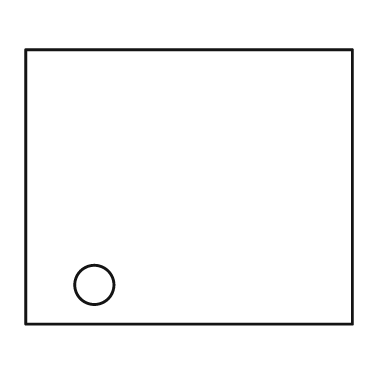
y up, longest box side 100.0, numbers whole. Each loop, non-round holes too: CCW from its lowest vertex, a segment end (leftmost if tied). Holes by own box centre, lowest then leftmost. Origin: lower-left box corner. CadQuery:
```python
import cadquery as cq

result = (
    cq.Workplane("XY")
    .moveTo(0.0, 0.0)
    .lineTo(100.0, 0.0)
    .lineTo(100.0, 84.0)
    .lineTo(0.0, 84.0)
    .close()
    .moveTo(21.0, 12.0)
    .circle(6.0)
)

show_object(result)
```